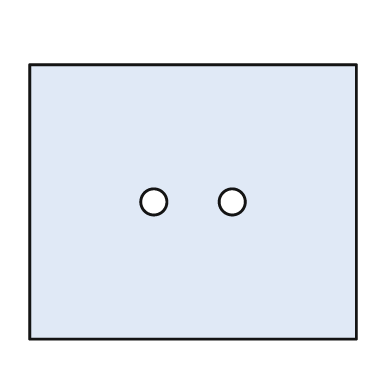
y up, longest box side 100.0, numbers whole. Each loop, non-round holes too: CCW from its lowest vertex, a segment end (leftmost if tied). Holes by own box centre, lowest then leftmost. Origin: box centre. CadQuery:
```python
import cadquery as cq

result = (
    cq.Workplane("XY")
    .moveTo(-50.0, -42.0)
    .lineTo(50.0, -42.0)
    .lineTo(50.0, 42.0)
    .lineTo(-50.0, 42.0)
    .close()
    .moveTo(-12.0, 0.0)
    .circle(4.0)
    .moveTo(12.0, 0.0)
    .circle(4.0)
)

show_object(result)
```